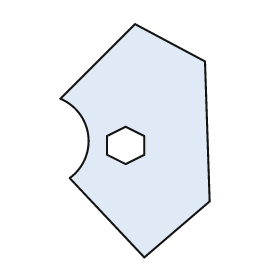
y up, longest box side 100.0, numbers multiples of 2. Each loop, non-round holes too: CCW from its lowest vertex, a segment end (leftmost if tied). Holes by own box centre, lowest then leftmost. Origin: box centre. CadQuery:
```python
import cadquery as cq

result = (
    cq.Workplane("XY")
    .moveTo(4.0, -50.0)
    .lineTo(32.0, -26.0)
    .lineTo(30.0, 34.0)
    .lineTo(0.0, 50.0)
    .lineTo(-32.0, 18.0)
    .threePointArc((-20.0, 2.0), (-28.0, -16.0))
    .close()
    .moveTo(-4.0, -10.0)
    .lineTo(4.0, -6.0)
    .lineTo(4.0, 2.0)
    .lineTo(-4.0, 6.0)
    .lineTo(-12.0, 2.0)
    .lineTo(-12.0, -6.0)
    .close()
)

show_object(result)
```